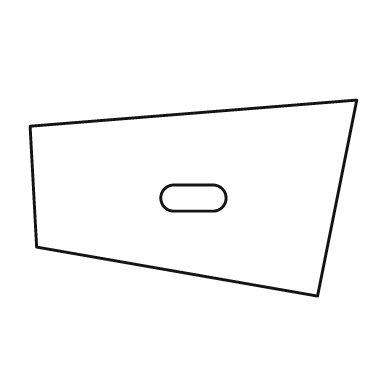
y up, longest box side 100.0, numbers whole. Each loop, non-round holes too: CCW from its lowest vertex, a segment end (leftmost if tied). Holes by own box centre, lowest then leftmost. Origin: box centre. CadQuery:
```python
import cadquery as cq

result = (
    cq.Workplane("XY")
    .moveTo(38.0, -30.0)
    .lineTo(50.0, 30.0)
    .lineTo(-50.0, 22.0)
    .lineTo(-48.0, -15.0)
    .close()
    .moveTo(-6.0, -4.0)
    .lineTo(6.0, -4.0)
    .threePointArc((10.0, 0.0), (6.0, 4.0))
    .lineTo(-6.0, 4.0)
    .threePointArc((-10.0, 0.0), (-6.0, -4.0))
    .close()
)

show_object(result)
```